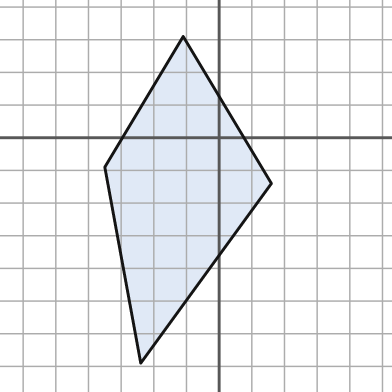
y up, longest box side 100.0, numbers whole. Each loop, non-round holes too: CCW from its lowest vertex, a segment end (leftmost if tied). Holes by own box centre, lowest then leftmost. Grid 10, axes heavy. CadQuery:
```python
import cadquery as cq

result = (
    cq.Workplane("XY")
    .moveTo(-24.0, -69.0)
    .lineTo(16.0, -14.0)
    .lineTo(-11.0, 31.0)
    .lineTo(-35.0, -9.0)
    .close()
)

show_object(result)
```